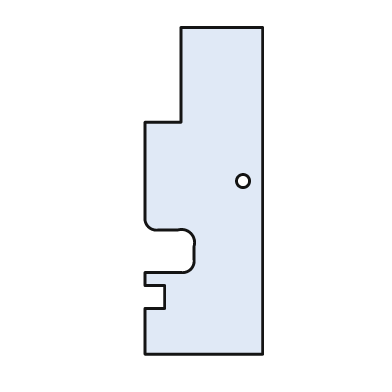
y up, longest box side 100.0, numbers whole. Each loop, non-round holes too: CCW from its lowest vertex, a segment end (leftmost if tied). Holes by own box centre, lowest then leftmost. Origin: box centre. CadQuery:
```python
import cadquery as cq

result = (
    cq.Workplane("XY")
    .moveTo(-18.0, -50.0)
    .lineTo(18.0, -50.0)
    .lineTo(18.0, 50.0)
    .lineTo(-7.0, 50.0)
    .lineTo(-7.0, 21.0)
    .lineTo(-18.0, 21.0)
    .lineTo(-18.0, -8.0)
    .threePointArc((-17.0, -11.0), (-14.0, -12.0))
    .lineTo(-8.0, -12.0)
    .threePointArc((-4.0, -13.0), (-3.0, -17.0))
    .lineTo(-3.0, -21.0)
    .threePointArc((-4.0, -24.0), (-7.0, -25.0))
    .lineTo(-18.0, -25.0)
    .lineTo(-18.0, -29.0)
    .lineTo(-12.0, -29.0)
    .lineTo(-12.0, -36.0)
    .lineTo(-18.0, -36.0)
    .close()
    .moveTo(12.0, 3.0)
    .circle(2.0)
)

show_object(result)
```